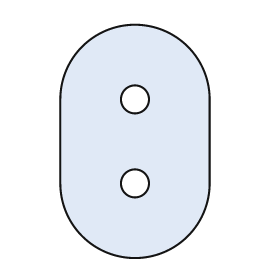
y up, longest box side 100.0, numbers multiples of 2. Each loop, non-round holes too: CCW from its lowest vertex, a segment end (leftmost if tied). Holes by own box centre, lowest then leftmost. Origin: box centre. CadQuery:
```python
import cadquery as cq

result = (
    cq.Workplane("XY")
    .moveTo(-32.0, -18.0)
    .threePointArc((0.0, -50.0), (32.0, -18.0))
    .lineTo(32.0, 18.0)
    .threePointArc((0.0, 50.0), (-32.0, 18.0))
    .close()
    .moveTo(0.0, -18.0)
    .circle(6.0)
    .moveTo(0.0, 18.0)
    .circle(6.0)
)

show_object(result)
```